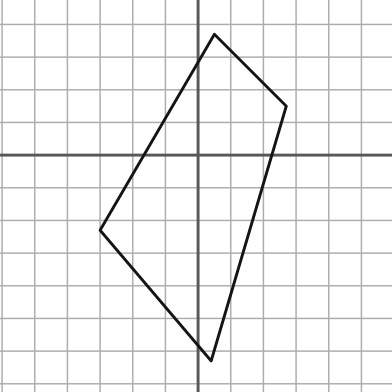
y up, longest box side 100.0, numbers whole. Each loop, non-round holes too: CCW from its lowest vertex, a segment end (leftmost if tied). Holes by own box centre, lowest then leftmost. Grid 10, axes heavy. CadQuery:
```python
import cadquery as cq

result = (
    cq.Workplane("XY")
    .moveTo(4.0, -63.0)
    .lineTo(27.0, 15.0)
    .lineTo(5.0, 37.0)
    .lineTo(-30.0, -23.0)
    .close()
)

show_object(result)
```